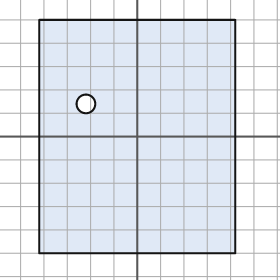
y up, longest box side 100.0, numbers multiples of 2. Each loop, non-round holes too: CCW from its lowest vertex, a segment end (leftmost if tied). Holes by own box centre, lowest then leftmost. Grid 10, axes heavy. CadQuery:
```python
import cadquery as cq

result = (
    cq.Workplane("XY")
    .moveTo(-42.0, -50.0)
    .lineTo(42.0, -50.0)
    .lineTo(42.0, 50.0)
    .lineTo(-42.0, 50.0)
    .close()
    .moveTo(-22.0, 14.0)
    .circle(4.0)
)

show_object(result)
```